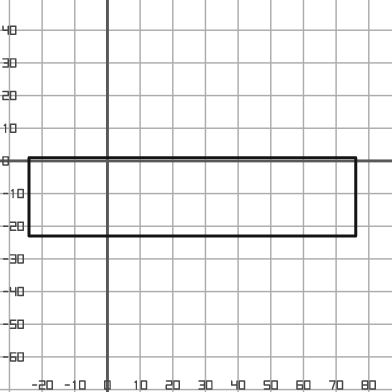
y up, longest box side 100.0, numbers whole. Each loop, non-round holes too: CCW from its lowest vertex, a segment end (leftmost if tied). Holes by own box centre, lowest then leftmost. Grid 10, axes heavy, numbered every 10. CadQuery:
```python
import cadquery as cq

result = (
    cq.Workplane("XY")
    .moveTo(-24.0, -23.0)
    .lineTo(76.0, -23.0)
    .lineTo(76.0, 1.0)
    .lineTo(-24.0, 1.0)
    .close()
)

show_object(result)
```